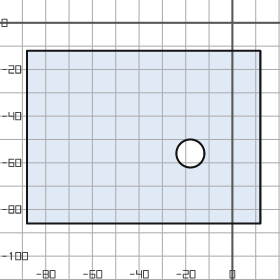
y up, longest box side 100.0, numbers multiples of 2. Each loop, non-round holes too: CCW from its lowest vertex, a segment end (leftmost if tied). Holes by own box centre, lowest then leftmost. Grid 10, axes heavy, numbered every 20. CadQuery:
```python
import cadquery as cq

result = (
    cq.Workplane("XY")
    .moveTo(-88.0, -86.0)
    .lineTo(12.0, -86.0)
    .lineTo(12.0, -12.0)
    .lineTo(-88.0, -12.0)
    .close()
    .moveTo(-18.0, -56.0)
    .circle(6.0)
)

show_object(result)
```